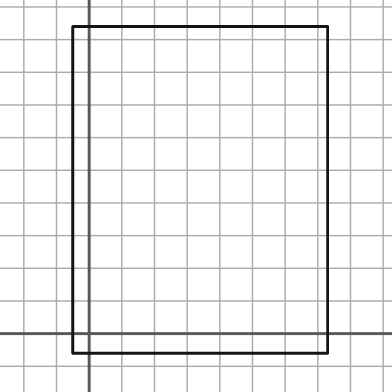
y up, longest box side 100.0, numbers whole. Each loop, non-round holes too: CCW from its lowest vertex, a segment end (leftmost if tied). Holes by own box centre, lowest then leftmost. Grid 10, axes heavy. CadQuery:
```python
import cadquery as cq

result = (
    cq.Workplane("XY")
    .moveTo(-5.0, -6.0)
    .lineTo(73.0, -6.0)
    .lineTo(73.0, 94.0)
    .lineTo(-5.0, 94.0)
    .close()
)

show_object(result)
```